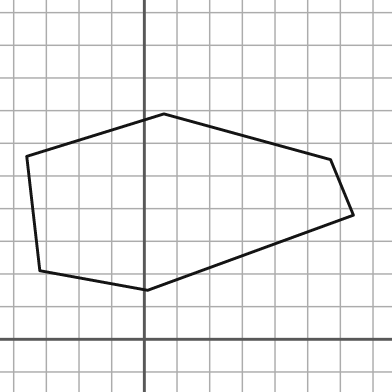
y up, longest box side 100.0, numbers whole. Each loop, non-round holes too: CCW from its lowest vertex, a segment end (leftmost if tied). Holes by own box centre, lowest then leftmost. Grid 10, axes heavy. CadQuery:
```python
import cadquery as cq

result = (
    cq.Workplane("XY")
    .moveTo(1.0, 15.0)
    .lineTo(64.0, 38.0)
    .lineTo(57.0, 55.0)
    .lineTo(6.0, 69.0)
    .lineTo(-36.0, 56.0)
    .lineTo(-32.0, 21.0)
    .close()
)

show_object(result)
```